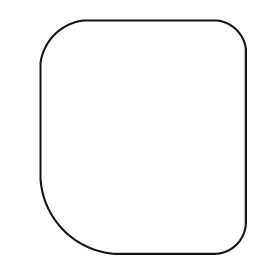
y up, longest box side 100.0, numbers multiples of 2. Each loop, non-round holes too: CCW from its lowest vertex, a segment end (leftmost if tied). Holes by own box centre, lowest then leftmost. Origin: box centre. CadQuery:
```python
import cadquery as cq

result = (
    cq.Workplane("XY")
    .moveTo(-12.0, -50.0)
    .lineTo(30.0, -50.0)
    .threePointArc((40.0, -46.0), (44.0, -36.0))
    .lineTo(44.0, 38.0)
    .threePointArc((40.0, 46.0), (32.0, 50.0))
    .lineTo(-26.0, 50.0)
    .threePointArc((-38.0, 44.0), (-44.0, 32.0))
    .lineTo(-44.0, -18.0)
    .threePointArc((-34.0, -40.0), (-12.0, -50.0))
    .close()
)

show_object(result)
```